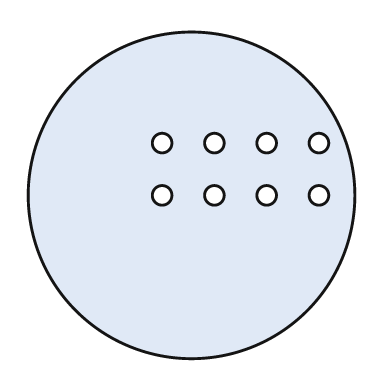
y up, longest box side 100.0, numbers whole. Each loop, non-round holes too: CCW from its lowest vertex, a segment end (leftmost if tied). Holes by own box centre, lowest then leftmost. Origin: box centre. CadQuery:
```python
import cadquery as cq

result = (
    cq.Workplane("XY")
    .moveTo(0.0, 0.0)
    .circle(50.0)
    .moveTo(-9.0, 0.0)
    .circle(3.0)
    .moveTo(7.0, 0.0)
    .circle(3.0)
    .moveTo(23.0, 0.0)
    .circle(3.0)
    .moveTo(39.0, 0.0)
    .circle(3.0)
    .moveTo(-9.0, 16.0)
    .circle(3.0)
    .moveTo(7.0, 16.0)
    .circle(3.0)
    .moveTo(23.0, 16.0)
    .circle(3.0)
    .moveTo(39.0, 16.0)
    .circle(3.0)
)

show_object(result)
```